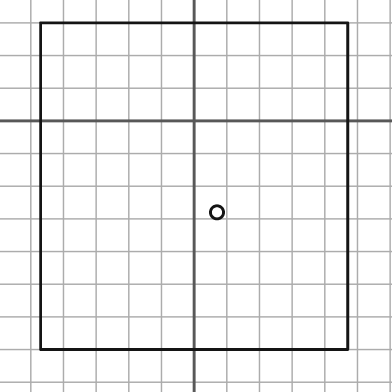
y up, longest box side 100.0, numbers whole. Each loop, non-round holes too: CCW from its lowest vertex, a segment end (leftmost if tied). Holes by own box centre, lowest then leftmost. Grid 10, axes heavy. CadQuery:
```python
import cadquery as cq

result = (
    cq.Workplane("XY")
    .moveTo(-47.0, -70.0)
    .lineTo(47.0, -70.0)
    .lineTo(47.0, 30.0)
    .lineTo(-47.0, 30.0)
    .close()
    .moveTo(7.0, -28.0)
    .circle(2.0)
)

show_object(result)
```